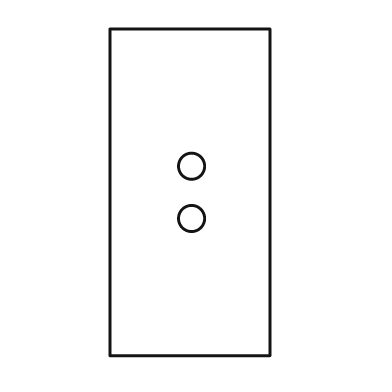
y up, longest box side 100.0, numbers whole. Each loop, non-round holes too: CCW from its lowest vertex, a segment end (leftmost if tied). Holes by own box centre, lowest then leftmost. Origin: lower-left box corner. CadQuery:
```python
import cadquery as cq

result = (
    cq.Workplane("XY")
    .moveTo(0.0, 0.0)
    .lineTo(49.0, 0.0)
    .lineTo(49.0, 100.0)
    .lineTo(0.0, 100.0)
    .close()
    .moveTo(25.0, 42.0)
    .circle(4.0)
    .moveTo(25.0, 58.0)
    .circle(4.0)
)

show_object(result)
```